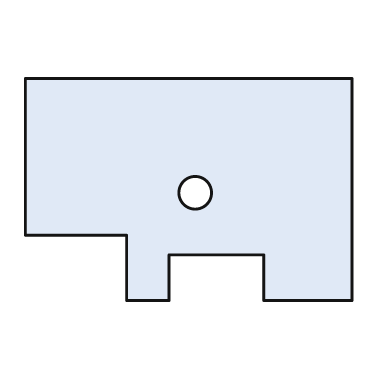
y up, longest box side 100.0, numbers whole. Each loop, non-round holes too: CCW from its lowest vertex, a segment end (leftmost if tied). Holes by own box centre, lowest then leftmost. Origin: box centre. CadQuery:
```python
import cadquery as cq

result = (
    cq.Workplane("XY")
    .moveTo(-19.0, -34.0)
    .lineTo(-6.0, -34.0)
    .lineTo(-6.0, -20.0)
    .lineTo(23.0, -20.0)
    .lineTo(23.0, -34.0)
    .lineTo(50.0, -34.0)
    .lineTo(50.0, 34.0)
    .lineTo(-50.0, 34.0)
    .lineTo(-50.0, -14.0)
    .lineTo(-19.0, -14.0)
    .close()
    .moveTo(2.0, -1.0)
    .circle(5.0)
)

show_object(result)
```